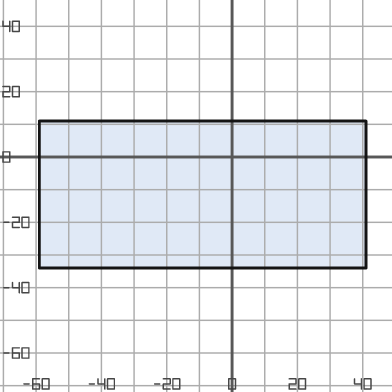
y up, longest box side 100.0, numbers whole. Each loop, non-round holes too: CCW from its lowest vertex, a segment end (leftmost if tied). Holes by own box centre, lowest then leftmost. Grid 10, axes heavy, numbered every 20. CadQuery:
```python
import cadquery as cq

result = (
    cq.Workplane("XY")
    .moveTo(-59.0, -34.0)
    .lineTo(41.0, -34.0)
    .lineTo(41.0, 11.0)
    .lineTo(-59.0, 11.0)
    .close()
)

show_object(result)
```